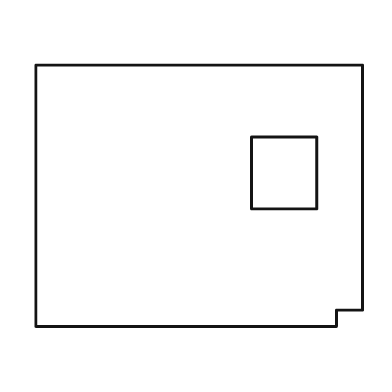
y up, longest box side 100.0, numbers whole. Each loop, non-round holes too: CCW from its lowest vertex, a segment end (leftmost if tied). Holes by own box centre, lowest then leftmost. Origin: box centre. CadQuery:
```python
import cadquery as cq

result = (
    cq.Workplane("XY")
    .moveTo(-50.0, -40.0)
    .lineTo(42.0, -40.0)
    .lineTo(42.0, -35.0)
    .lineTo(50.0, -35.0)
    .lineTo(50.0, 40.0)
    .lineTo(-50.0, 40.0)
    .close()
    .moveTo(16.0, -4.0)
    .lineTo(36.0, -4.0)
    .lineTo(36.0, 18.0)
    .lineTo(16.0, 18.0)
    .close()
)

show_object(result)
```